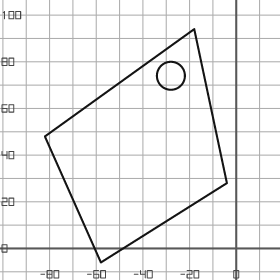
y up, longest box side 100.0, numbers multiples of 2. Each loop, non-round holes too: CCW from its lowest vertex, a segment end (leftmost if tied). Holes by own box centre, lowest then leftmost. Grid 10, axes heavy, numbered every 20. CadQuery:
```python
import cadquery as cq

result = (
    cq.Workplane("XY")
    .moveTo(-58.0, -6.0)
    .lineTo(-4.0, 28.0)
    .lineTo(-18.0, 94.0)
    .lineTo(-82.0, 48.0)
    .close()
    .moveTo(-28.0, 74.0)
    .circle(6.0)
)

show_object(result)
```